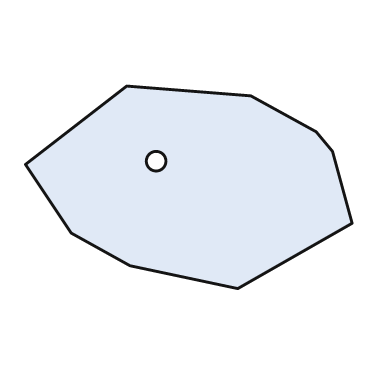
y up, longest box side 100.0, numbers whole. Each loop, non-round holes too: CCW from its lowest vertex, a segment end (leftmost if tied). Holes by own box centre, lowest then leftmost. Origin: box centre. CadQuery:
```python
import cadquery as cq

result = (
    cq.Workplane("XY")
    .moveTo(15.0, -31.0)
    .lineTo(50.0, -11.0)
    .lineTo(44.0, 11.0)
    .lineTo(39.0, 17.0)
    .lineTo(19.0, 28.0)
    .lineTo(-19.0, 31.0)
    .lineTo(-50.0, 7.0)
    .lineTo(-36.0, -14.0)
    .lineTo(-18.0, -24.0)
    .close()
    .moveTo(-10.0, 8.0)
    .circle(3.0)
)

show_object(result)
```